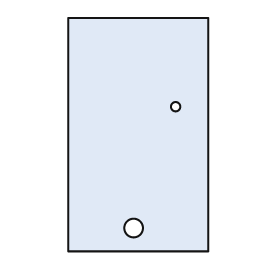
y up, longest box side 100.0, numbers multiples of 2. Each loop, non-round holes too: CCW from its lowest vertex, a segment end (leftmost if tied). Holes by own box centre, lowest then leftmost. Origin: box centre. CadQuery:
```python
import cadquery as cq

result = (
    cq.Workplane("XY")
    .moveTo(-30.0, -50.0)
    .lineTo(30.0, -50.0)
    .lineTo(30.0, 50.0)
    .lineTo(-30.0, 50.0)
    .close()
    .moveTo(-2.0, -40.0)
    .circle(4.0)
    .moveTo(16.0, 12.0)
    .circle(2.0)
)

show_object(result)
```